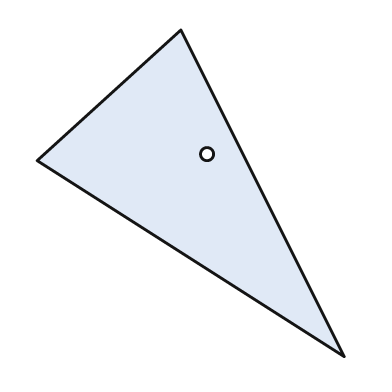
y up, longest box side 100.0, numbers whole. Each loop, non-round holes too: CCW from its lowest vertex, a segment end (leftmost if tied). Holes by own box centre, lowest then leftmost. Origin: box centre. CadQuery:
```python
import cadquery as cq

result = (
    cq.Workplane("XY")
    .moveTo(47.0, -50.0)
    .lineTo(-3.0, 50.0)
    .lineTo(-47.0, 10.0)
    .close()
    .moveTo(5.0, 12.0)
    .circle(2.0)
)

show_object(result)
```